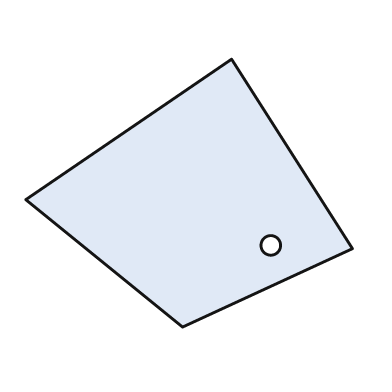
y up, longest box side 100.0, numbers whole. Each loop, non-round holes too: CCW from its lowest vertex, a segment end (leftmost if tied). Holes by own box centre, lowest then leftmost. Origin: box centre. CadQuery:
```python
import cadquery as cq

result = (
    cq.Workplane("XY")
    .moveTo(-2.0, -41.0)
    .lineTo(50.0, -17.0)
    .lineTo(13.0, 41.0)
    .lineTo(-50.0, -2.0)
    .close()
    .moveTo(25.0, -16.0)
    .circle(3.0)
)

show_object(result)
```